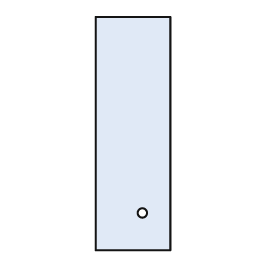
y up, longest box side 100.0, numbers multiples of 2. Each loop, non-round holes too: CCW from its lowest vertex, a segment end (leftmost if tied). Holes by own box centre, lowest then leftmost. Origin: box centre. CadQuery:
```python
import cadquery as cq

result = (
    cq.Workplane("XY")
    .moveTo(-16.0, -50.0)
    .lineTo(16.0, -50.0)
    .lineTo(16.0, 50.0)
    .lineTo(-16.0, 50.0)
    .close()
    .moveTo(4.0, -34.0)
    .circle(2.0)
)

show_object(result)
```